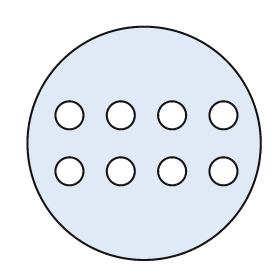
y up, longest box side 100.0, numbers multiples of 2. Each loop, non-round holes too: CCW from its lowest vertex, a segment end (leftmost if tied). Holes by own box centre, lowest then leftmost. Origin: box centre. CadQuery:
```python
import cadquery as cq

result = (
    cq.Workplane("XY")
    .moveTo(0.0, 0.0)
    .circle(50.0)
    .moveTo(-32.0, -12.0)
    .circle(6.0)
    .moveTo(-10.0, -12.0)
    .circle(6.0)
    .moveTo(12.0, -12.0)
    .circle(6.0)
    .moveTo(34.0, -12.0)
    .circle(6.0)
    .moveTo(-32.0, 12.0)
    .circle(6.0)
    .moveTo(-10.0, 12.0)
    .circle(6.0)
    .moveTo(12.0, 12.0)
    .circle(6.0)
    .moveTo(34.0, 12.0)
    .circle(6.0)
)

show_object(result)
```